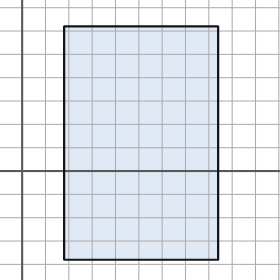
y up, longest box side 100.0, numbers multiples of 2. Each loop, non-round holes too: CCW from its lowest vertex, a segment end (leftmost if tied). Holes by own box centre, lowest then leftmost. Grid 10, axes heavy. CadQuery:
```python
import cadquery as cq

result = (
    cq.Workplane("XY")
    .moveTo(18.0, -38.0)
    .lineTo(84.0, -38.0)
    .lineTo(84.0, 62.0)
    .lineTo(18.0, 62.0)
    .close()
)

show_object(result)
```